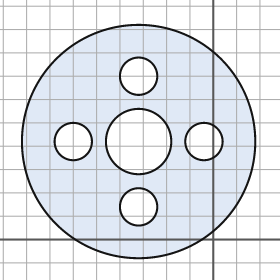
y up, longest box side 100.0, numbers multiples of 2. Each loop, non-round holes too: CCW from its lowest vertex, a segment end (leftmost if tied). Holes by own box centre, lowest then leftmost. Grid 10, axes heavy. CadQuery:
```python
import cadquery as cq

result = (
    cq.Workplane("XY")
    .moveTo(-32.0, 42.0)
    .circle(50.0)
    .moveTo(-32.0, 14.0)
    .circle(8.0)
    .moveTo(-60.0, 42.0)
    .circle(8.0)
    .moveTo(-32.0, 42.0)
    .circle(14.0)
    .moveTo(-4.0, 42.0)
    .circle(8.0)
    .moveTo(-32.0, 70.0)
    .circle(8.0)
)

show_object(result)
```